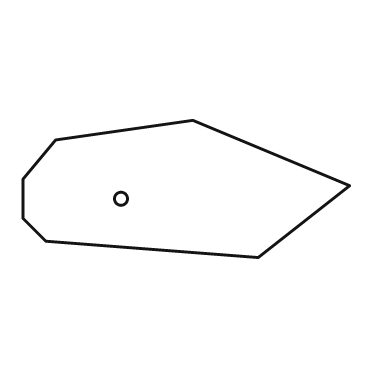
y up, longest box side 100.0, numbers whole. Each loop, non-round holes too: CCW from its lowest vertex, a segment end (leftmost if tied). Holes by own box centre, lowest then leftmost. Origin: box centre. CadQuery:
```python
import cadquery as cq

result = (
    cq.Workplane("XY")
    .moveTo(22.0, -21.0)
    .lineTo(50.0, 1.0)
    .lineTo(2.0, 21.0)
    .lineTo(-40.0, 15.0)
    .lineTo(-50.0, 3.0)
    .lineTo(-50.0, -9.0)
    .lineTo(-43.0, -16.0)
    .close()
    .moveTo(-20.0, -3.0)
    .circle(2.0)
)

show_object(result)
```